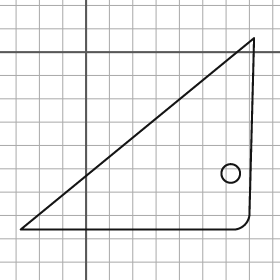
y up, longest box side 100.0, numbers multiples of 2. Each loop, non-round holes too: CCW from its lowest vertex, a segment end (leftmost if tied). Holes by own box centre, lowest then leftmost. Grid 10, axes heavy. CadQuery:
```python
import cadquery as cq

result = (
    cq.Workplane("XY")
    .moveTo(-28.0, -76.0)
    .lineTo(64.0, -76.0)
    .threePointArc((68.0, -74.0), (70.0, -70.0))
    .lineTo(72.0, 6.0)
    .close()
    .moveTo(62.0, -52.0)
    .circle(4.0)
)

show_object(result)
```